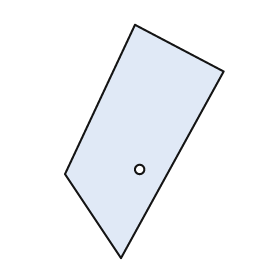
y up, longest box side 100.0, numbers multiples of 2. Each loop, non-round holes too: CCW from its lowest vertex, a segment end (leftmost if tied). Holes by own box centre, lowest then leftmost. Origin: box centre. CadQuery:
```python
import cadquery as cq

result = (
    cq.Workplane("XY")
    .moveTo(-10.0, -50.0)
    .lineTo(34.0, 30.0)
    .lineTo(-4.0, 50.0)
    .lineTo(-34.0, -14.0)
    .close()
    .moveTo(-2.0, -12.0)
    .circle(2.0)
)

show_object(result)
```